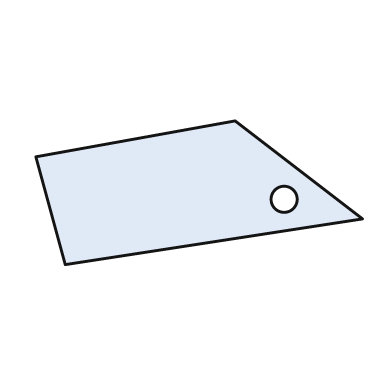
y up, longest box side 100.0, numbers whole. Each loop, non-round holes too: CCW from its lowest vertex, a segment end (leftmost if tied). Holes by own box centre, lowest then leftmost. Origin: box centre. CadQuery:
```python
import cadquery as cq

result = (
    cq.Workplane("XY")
    .moveTo(-41.0, -22.0)
    .lineTo(50.0, -8.0)
    .lineTo(11.0, 22.0)
    .lineTo(-50.0, 11.0)
    .close()
    .moveTo(26.0, -2.0)
    .circle(4.0)
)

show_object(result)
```